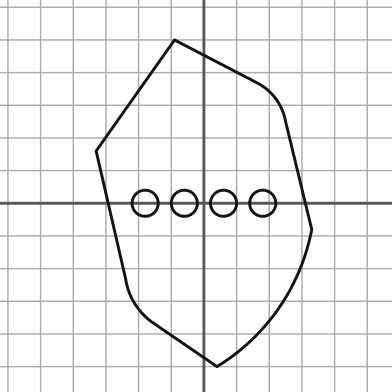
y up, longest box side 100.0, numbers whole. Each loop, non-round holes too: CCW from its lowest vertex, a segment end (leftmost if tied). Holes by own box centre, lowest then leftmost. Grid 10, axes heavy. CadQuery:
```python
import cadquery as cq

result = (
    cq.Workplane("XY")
    .moveTo(4.0, -50.0)
    .threePointArc((23.0, -32.0), (33.0, -8.0))
    .lineTo(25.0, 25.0)
    .threePointArc((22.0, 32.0), (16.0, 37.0))
    .lineTo(-9.0, 50.0)
    .lineTo(-33.0, 16.0)
    .lineTo(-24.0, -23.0)
    .threePointArc((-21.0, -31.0), (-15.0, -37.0))
    .close()
    .moveTo(-18.0, 0.0)
    .circle(4.0)
    .moveTo(-6.0, 0.0)
    .circle(4.0)
    .moveTo(6.0, 0.0)
    .circle(4.0)
    .moveTo(18.0, 0.0)
    .circle(4.0)
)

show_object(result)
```